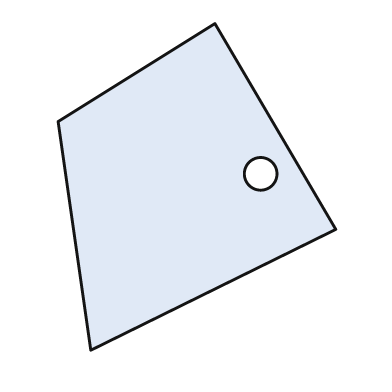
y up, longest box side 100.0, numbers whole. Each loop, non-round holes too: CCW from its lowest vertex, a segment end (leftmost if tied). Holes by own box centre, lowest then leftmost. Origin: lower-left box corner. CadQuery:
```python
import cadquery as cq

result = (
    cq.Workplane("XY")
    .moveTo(10.0, 0.0)
    .lineTo(85.0, 37.0)
    .lineTo(48.0, 100.0)
    .lineTo(0.0, 70.0)
    .close()
    .moveTo(62.0, 54.0)
    .circle(5.0)
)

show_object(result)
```